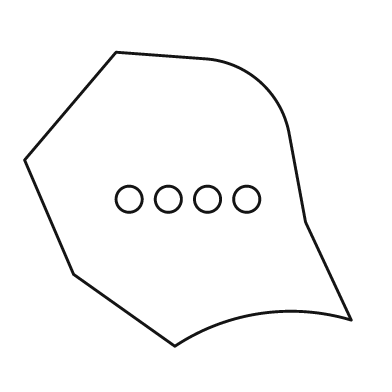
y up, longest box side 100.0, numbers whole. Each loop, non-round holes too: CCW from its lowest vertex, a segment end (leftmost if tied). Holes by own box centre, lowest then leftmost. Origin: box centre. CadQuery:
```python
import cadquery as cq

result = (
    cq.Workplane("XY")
    .moveTo(-4.0, -45.0)
    .threePointArc((22.0, -35.0), (50.0, -37.0))
    .lineTo(36.0, -7.0)
    .lineTo(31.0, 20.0)
    .threePointArc((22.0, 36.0), (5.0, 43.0))
    .lineTo(-22.0, 45.0)
    .lineTo(-50.0, 12.0)
    .lineTo(-35.0, -23.0)
    .close()
    .moveTo(-18.0, 0.0)
    .circle(4.0)
    .moveTo(-6.0, 0.0)
    .circle(4.0)
    .moveTo(6.0, 0.0)
    .circle(4.0)
    .moveTo(18.0, 0.0)
    .circle(4.0)
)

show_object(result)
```